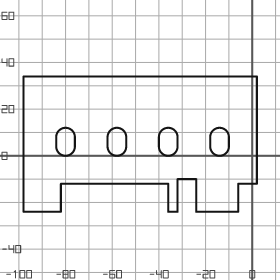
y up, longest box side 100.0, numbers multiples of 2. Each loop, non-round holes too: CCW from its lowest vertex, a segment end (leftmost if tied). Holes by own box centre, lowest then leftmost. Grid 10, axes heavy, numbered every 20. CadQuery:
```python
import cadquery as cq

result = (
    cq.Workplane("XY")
    .moveTo(-98.0, -24.0)
    .lineTo(-82.0, -24.0)
    .lineTo(-82.0, -12.0)
    .lineTo(-36.0, -12.0)
    .lineTo(-36.0, -24.0)
    .lineTo(-32.0, -24.0)
    .lineTo(-32.0, -10.0)
    .lineTo(-24.0, -10.0)
    .lineTo(-24.0, -24.0)
    .lineTo(-6.0, -24.0)
    .lineTo(-6.0, -12.0)
    .lineTo(2.0, -12.0)
    .lineTo(2.0, 34.0)
    .lineTo(-98.0, 34.0)
    .close()
    .moveTo(-84.0, 4.0)
    .threePointArc((-80.0, 0.0), (-76.0, 4.0))
    .lineTo(-76.0, 8.0)
    .threePointArc((-80.0, 12.0), (-84.0, 8.0))
    .close()
    .moveTo(-62.0, 4.0)
    .threePointArc((-58.0, 0.0), (-54.0, 4.0))
    .lineTo(-54.0, 8.0)
    .threePointArc((-58.0, 12.0), (-62.0, 8.0))
    .close()
    .moveTo(-40.0, 4.0)
    .threePointArc((-36.0, 0.0), (-32.0, 4.0))
    .lineTo(-32.0, 8.0)
    .threePointArc((-36.0, 12.0), (-40.0, 8.0))
    .close()
    .moveTo(-18.0, 4.0)
    .threePointArc((-14.0, 0.0), (-10.0, 4.0))
    .lineTo(-10.0, 8.0)
    .threePointArc((-14.0, 12.0), (-18.0, 8.0))
    .close()
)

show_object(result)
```